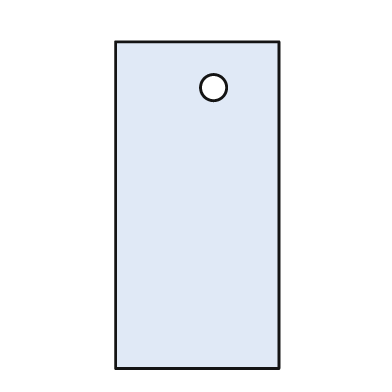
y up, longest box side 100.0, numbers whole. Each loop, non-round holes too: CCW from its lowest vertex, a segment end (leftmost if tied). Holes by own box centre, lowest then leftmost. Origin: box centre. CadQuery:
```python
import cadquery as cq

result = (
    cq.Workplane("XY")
    .moveTo(-25.0, -50.0)
    .lineTo(25.0, -50.0)
    .lineTo(25.0, 50.0)
    .lineTo(-25.0, 50.0)
    .close()
    .moveTo(5.0, 36.0)
    .circle(4.0)
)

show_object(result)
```